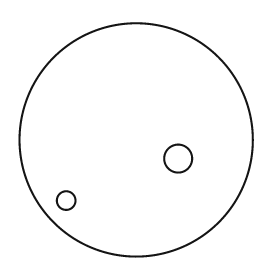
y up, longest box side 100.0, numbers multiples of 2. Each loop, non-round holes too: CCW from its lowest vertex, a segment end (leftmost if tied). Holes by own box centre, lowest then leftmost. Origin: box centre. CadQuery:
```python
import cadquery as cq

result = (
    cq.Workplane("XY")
    .moveTo(0.0, 0.0)
    .circle(50.0)
    .moveTo(-30.0, -26.0)
    .circle(4.0)
    .moveTo(18.0, -8.0)
    .circle(6.0)
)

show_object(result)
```